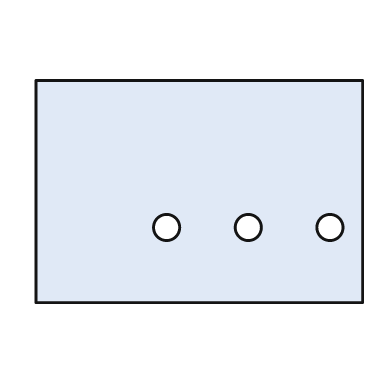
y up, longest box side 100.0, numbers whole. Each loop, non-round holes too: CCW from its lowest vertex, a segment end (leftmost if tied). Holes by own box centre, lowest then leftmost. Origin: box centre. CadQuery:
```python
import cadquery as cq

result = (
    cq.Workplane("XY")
    .moveTo(-50.0, -34.0)
    .lineTo(50.0, -34.0)
    .lineTo(50.0, 34.0)
    .lineTo(-50.0, 34.0)
    .close()
    .moveTo(-10.0, -11.0)
    .circle(4.0)
    .moveTo(15.0, -11.0)
    .circle(4.0)
    .moveTo(40.0, -11.0)
    .circle(4.0)
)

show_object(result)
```